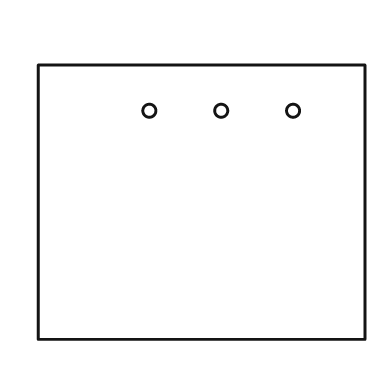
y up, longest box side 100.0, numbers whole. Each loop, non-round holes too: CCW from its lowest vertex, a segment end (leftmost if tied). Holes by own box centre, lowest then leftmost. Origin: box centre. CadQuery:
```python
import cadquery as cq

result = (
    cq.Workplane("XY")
    .moveTo(-50.0, -42.0)
    .lineTo(50.0, -42.0)
    .lineTo(50.0, 42.0)
    .lineTo(-50.0, 42.0)
    .close()
    .moveTo(-16.0, 28.0)
    .circle(2.0)
    .moveTo(6.0, 28.0)
    .circle(2.0)
    .moveTo(28.0, 28.0)
    .circle(2.0)
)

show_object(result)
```